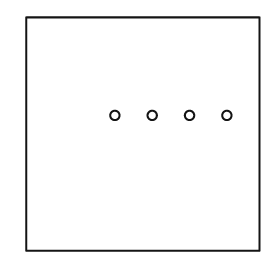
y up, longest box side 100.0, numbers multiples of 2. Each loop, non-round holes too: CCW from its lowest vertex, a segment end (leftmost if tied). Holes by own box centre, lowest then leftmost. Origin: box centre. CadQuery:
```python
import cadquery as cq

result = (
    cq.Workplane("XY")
    .moveTo(-50.0, -50.0)
    .lineTo(50.0, -50.0)
    .lineTo(50.0, 50.0)
    .lineTo(-50.0, 50.0)
    .close()
    .moveTo(-12.0, 8.0)
    .circle(2.0)
    .moveTo(4.0, 8.0)
    .circle(2.0)
    .moveTo(20.0, 8.0)
    .circle(2.0)
    .moveTo(36.0, 8.0)
    .circle(2.0)
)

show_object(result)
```